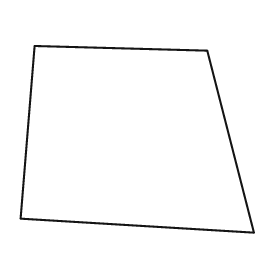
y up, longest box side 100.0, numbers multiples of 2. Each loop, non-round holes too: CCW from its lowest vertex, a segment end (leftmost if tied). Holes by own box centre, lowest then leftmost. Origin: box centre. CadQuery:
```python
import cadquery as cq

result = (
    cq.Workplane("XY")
    .moveTo(50.0, -40.0)
    .lineTo(30.0, 38.0)
    .lineTo(-44.0, 40.0)
    .lineTo(-50.0, -34.0)
    .close()
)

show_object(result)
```